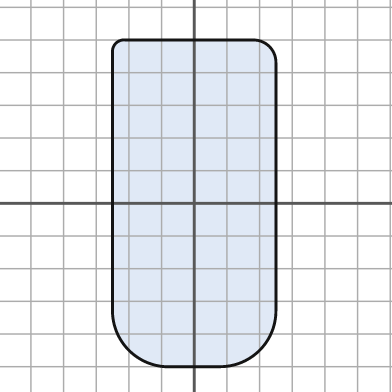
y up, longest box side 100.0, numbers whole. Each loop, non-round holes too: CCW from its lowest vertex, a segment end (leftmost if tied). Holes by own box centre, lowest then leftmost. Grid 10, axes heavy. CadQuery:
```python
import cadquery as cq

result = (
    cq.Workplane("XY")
    .moveTo(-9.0, -50.0)
    .lineTo(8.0, -50.0)
    .threePointArc((20.0, -45.0), (25.0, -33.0))
    .lineTo(25.0, 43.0)
    .threePointArc((23.0, 48.0), (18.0, 50.0))
    .lineTo(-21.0, 50.0)
    .threePointArc((-24.0, 49.0), (-25.0, 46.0))
    .lineTo(-25.0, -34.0)
    .threePointArc((-20.0, -45.0), (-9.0, -50.0))
    .close()
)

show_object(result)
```